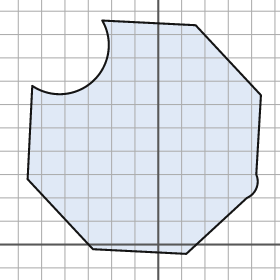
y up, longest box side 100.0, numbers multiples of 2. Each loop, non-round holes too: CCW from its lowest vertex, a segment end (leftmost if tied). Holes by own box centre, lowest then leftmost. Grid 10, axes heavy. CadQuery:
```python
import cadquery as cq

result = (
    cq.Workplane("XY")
    .moveTo(12.0, -4.0)
    .lineTo(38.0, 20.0)
    .threePointArc((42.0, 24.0), (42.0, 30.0))
    .lineTo(44.0, 64.0)
    .lineTo(16.0, 94.0)
    .lineTo(-24.0, 96.0)
    .threePointArc((-28.0, 70.0), (-54.0, 68.0))
    .lineTo(-56.0, 28.0)
    .lineTo(-28.0, -2.0)
    .close()
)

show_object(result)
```